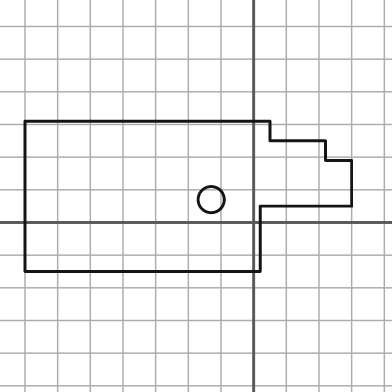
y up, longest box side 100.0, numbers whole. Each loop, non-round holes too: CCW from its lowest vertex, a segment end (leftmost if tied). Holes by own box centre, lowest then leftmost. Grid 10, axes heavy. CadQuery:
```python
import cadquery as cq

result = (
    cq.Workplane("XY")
    .moveTo(-70.0, -15.0)
    .lineTo(2.0, -15.0)
    .lineTo(2.0, 5.0)
    .lineTo(30.0, 5.0)
    .lineTo(30.0, 19.0)
    .lineTo(22.0, 19.0)
    .lineTo(22.0, 25.0)
    .lineTo(5.0, 25.0)
    .lineTo(5.0, 31.0)
    .lineTo(-70.0, 31.0)
    .close()
    .moveTo(-13.0, 7.0)
    .circle(4.0)
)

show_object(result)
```